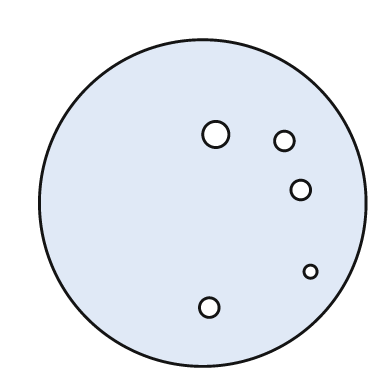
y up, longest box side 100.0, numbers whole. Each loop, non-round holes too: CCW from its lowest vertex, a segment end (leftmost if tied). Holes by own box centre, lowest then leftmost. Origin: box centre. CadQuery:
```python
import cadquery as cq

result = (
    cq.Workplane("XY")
    .moveTo(0.0, 0.0)
    .circle(50.0)
    .moveTo(2.0, -32.0)
    .circle(3.0)
    .moveTo(33.0, -21.0)
    .circle(2.0)
    .moveTo(30.0, 4.0)
    .circle(3.0)
    .moveTo(25.0, 19.0)
    .circle(3.0)
    .moveTo(4.0, 21.0)
    .circle(4.0)
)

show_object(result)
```